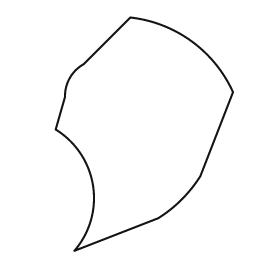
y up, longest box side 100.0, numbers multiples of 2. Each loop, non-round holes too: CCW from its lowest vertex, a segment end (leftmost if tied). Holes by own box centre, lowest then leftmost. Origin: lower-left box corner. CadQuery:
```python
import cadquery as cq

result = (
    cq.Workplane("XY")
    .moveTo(8.0, 0.0)
    .lineTo(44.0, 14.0)
    .threePointArc((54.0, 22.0), (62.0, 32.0))
    .lineTo(76.0, 68.0)
    .threePointArc((58.0, 90.0), (32.0, 100.0))
    .lineTo(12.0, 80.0)
    .threePointArc((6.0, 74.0), (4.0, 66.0))
    .lineTo(0.0, 52.0)
    .threePointArc((16.0, 28.0), (8.0, 0.0))
    .close()
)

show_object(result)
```